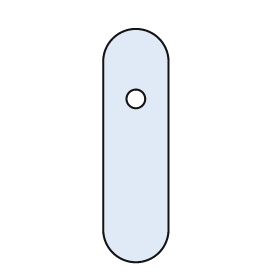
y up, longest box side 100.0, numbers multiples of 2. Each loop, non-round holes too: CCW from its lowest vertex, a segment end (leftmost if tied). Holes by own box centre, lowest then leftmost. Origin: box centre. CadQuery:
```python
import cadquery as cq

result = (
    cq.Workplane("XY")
    .moveTo(-14.0, -36.0)
    .threePointArc((0.0, -50.0), (14.0, -36.0))
    .lineTo(14.0, 36.0)
    .threePointArc((0.0, 50.0), (-14.0, 36.0))
    .close()
    .moveTo(0.0, 20.0)
    .circle(4.0)
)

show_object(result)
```